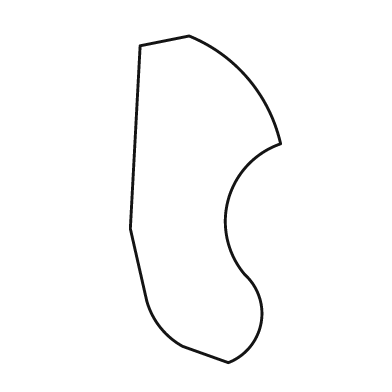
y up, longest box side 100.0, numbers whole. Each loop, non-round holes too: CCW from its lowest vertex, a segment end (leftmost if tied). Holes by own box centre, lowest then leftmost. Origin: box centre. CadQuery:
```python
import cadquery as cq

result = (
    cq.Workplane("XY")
    .moveTo(7.0, -50.0)
    .threePointArc((17.0, -38.0), (12.0, -23.0))
    .threePointArc((7.0, 0.0), (23.0, 17.0))
    .threePointArc((13.0, 37.0), (-5.0, 50.0))
    .lineTo(-20.0, 47.0)
    .lineTo(-23.0, -9.0)
    .lineTo(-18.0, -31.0)
    .threePointArc((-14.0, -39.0), (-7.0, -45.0))
    .close()
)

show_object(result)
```